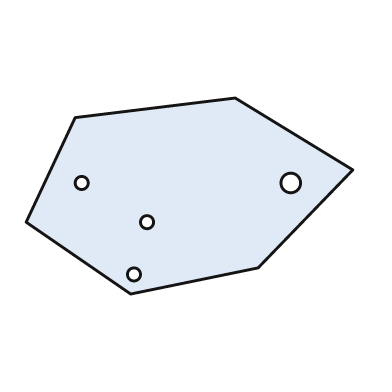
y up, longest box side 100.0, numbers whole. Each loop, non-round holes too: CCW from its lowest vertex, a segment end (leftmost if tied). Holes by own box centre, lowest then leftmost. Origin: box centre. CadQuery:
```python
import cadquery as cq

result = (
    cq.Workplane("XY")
    .moveTo(-18.0, -30.0)
    .lineTo(21.0, -22.0)
    .lineTo(50.0, 8.0)
    .lineTo(14.0, 30.0)
    .lineTo(-35.0, 24.0)
    .lineTo(-50.0, -8.0)
    .close()
    .moveTo(-17.0, -24.0)
    .circle(2.0)
    .moveTo(-13.0, -8.0)
    .circle(2.0)
    .moveTo(-33.0, 4.0)
    .circle(2.0)
    .moveTo(31.0, 4.0)
    .circle(3.0)
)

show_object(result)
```